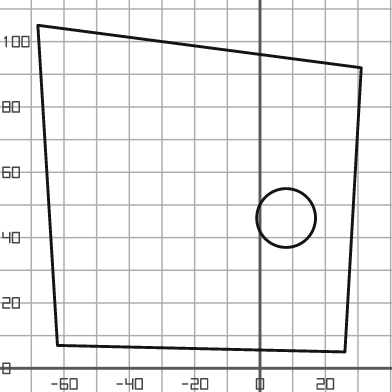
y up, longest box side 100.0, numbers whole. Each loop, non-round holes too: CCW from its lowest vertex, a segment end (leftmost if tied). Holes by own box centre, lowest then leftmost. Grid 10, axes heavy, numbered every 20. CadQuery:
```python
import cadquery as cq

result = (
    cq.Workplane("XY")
    .moveTo(26.0, 5.0)
    .lineTo(31.0, 92.0)
    .lineTo(-68.0, 105.0)
    .lineTo(-62.0, 7.0)
    .close()
    .moveTo(8.0, 46.0)
    .circle(9.0)
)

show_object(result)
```